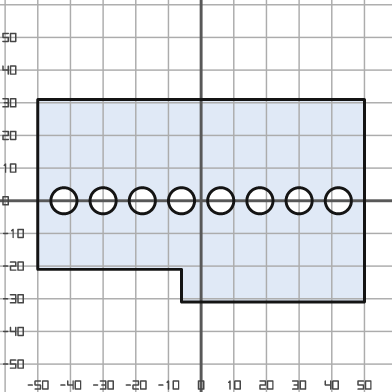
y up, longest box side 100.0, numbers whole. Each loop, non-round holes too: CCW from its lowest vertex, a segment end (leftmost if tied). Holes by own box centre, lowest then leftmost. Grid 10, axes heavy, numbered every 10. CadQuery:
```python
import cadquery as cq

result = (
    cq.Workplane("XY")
    .moveTo(-6.0, -31.0)
    .lineTo(50.0, -31.0)
    .lineTo(50.0, 31.0)
    .lineTo(-50.0, 31.0)
    .lineTo(-50.0, -21.0)
    .lineTo(-6.0, -21.0)
    .close()
    .moveTo(-42.0, 0.0)
    .circle(4.0)
    .moveTo(-30.0, 0.0)
    .circle(4.0)
    .moveTo(-18.0, 0.0)
    .circle(4.0)
    .moveTo(-6.0, 0.0)
    .circle(4.0)
    .moveTo(6.0, 0.0)
    .circle(4.0)
    .moveTo(18.0, 0.0)
    .circle(4.0)
    .moveTo(30.0, 0.0)
    .circle(4.0)
    .moveTo(42.0, 0.0)
    .circle(4.0)
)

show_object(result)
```